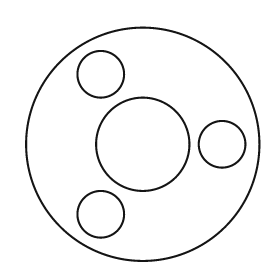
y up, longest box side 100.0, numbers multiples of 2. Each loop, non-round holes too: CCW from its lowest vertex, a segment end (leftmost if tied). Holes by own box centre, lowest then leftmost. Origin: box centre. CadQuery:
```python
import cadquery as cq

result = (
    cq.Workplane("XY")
    .moveTo(0.0, 0.0)
    .circle(50.0)
    .moveTo(-18.0, -30.0)
    .circle(10.0)
    .moveTo(0.0, 0.0)
    .circle(20.0)
    .moveTo(34.0, 0.0)
    .circle(10.0)
    .moveTo(-18.0, 30.0)
    .circle(10.0)
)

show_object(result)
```